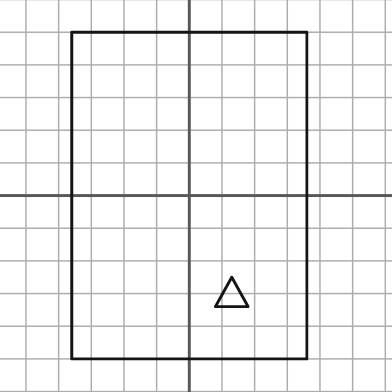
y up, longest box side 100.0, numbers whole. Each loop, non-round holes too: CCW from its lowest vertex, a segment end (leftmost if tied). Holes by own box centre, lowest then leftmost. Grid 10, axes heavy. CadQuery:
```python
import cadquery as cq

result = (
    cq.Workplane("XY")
    .moveTo(-36.0, -50.0)
    .lineTo(36.0, -50.0)
    .lineTo(36.0, 50.0)
    .lineTo(-36.0, 50.0)
    .close()
    .moveTo(8.0, -34.0)
    .lineTo(18.0, -34.0)
    .lineTo(13.0, -25.0)
    .close()
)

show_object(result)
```